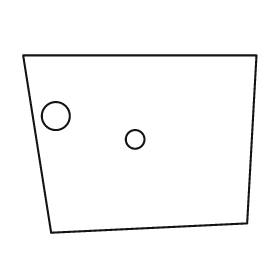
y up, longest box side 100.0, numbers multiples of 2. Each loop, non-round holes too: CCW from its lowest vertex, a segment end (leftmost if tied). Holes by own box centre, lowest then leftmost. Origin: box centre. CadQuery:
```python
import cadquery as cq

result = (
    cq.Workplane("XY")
    .moveTo(-38.0, -38.0)
    .lineTo(46.0, -34.0)
    .lineTo(50.0, 38.0)
    .lineTo(-50.0, 38.0)
    .close()
    .moveTo(-2.0, 2.0)
    .circle(4.0)
    .moveTo(-36.0, 12.0)
    .circle(6.0)
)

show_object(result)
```